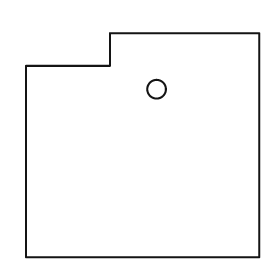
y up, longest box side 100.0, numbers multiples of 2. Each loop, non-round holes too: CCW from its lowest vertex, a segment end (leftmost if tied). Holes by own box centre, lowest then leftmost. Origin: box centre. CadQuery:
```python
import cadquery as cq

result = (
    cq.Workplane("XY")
    .moveTo(-50.0, -48.0)
    .lineTo(50.0, -48.0)
    .lineTo(50.0, 48.0)
    .lineTo(-14.0, 48.0)
    .lineTo(-14.0, 34.0)
    .lineTo(-50.0, 34.0)
    .close()
    .moveTo(6.0, 24.0)
    .circle(4.0)
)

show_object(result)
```